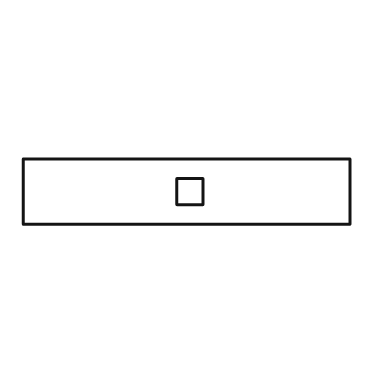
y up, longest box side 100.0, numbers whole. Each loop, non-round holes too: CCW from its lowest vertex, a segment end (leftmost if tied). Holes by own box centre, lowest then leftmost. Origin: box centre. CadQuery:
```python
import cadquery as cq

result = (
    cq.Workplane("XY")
    .moveTo(-50.0, -10.0)
    .lineTo(50.0, -10.0)
    .lineTo(50.0, 10.0)
    .lineTo(-50.0, 10.0)
    .close()
    .moveTo(-3.0, -4.0)
    .lineTo(5.0, -4.0)
    .lineTo(5.0, 4.0)
    .lineTo(-3.0, 4.0)
    .close()
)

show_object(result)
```